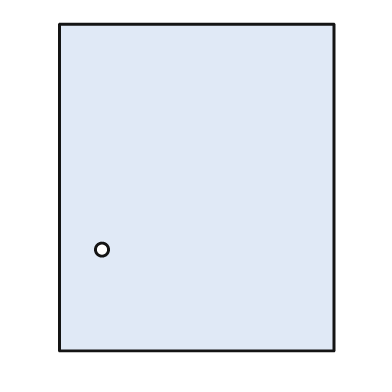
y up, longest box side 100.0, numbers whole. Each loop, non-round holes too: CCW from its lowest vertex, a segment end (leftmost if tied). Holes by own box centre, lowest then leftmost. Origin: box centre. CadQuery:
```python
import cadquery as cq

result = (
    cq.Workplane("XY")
    .moveTo(-42.0, -50.0)
    .lineTo(42.0, -50.0)
    .lineTo(42.0, 50.0)
    .lineTo(-42.0, 50.0)
    .close()
    .moveTo(-29.0, -19.0)
    .circle(2.0)
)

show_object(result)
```